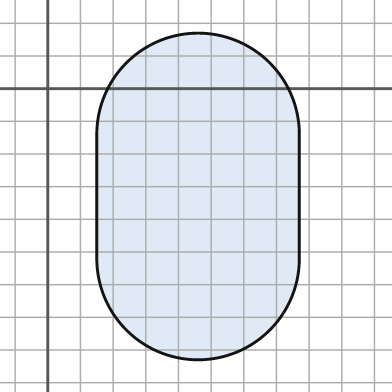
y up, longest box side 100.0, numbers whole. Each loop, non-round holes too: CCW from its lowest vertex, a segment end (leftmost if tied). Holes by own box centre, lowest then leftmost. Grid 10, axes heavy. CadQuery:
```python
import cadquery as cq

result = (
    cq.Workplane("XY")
    .moveTo(15.0, -52.0)
    .threePointArc((46.0, -83.0), (77.0, -52.0))
    .lineTo(77.0, -14.0)
    .threePointArc((46.0, 17.0), (15.0, -14.0))
    .close()
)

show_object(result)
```